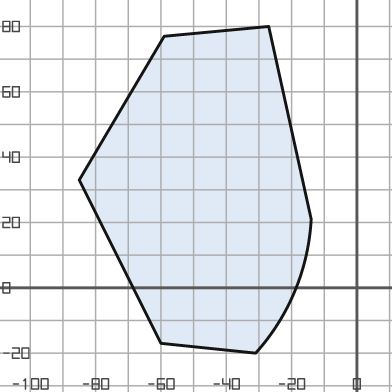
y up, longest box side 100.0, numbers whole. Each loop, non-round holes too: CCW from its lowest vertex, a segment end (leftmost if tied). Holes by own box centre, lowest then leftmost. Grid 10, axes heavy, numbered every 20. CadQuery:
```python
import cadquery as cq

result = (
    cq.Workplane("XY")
    .moveTo(-31.0, -20.0)
    .threePointArc((-19.0, -1.0), (-14.0, 21.0))
    .lineTo(-27.0, 80.0)
    .lineTo(-59.0, 77.0)
    .lineTo(-85.0, 33.0)
    .lineTo(-60.0, -17.0)
    .close()
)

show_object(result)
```